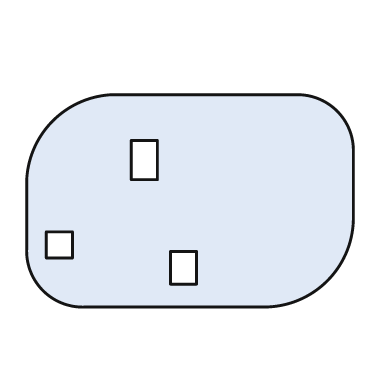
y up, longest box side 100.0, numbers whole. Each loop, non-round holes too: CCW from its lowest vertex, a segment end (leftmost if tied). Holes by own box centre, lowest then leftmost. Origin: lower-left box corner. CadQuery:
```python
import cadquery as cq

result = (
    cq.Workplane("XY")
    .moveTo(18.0, 0.0)
    .lineTo(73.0, 0.0)
    .threePointArc((92.0, 8.0), (100.0, 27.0))
    .lineTo(100.0, 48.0)
    .threePointArc((95.0, 60.0), (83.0, 65.0))
    .lineTo(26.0, 65.0)
    .threePointArc((8.0, 57.0), (0.0, 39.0))
    .lineTo(0.0, 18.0)
    .threePointArc((5.0, 5.0), (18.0, 0.0))
    .close()
    .moveTo(44.0, 7.0)
    .lineTo(52.0, 7.0)
    .lineTo(52.0, 17.0)
    .lineTo(44.0, 17.0)
    .close()
    .moveTo(6.0, 15.0)
    .lineTo(14.0, 15.0)
    .lineTo(14.0, 23.0)
    .lineTo(6.0, 23.0)
    .close()
    .moveTo(32.0, 39.0)
    .lineTo(40.0, 39.0)
    .lineTo(40.0, 51.0)
    .lineTo(32.0, 51.0)
    .close()
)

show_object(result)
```